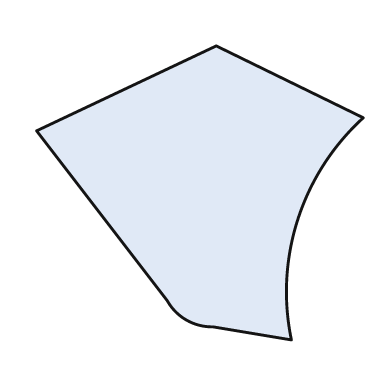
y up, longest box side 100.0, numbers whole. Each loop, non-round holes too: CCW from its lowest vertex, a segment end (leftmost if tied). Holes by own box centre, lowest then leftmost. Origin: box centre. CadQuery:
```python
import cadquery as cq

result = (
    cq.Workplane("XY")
    .moveTo(28.0, -45.0)
    .threePointArc((30.0, -8.0), (50.0, 23.0))
    .lineTo(5.0, 45.0)
    .lineTo(-50.0, 19.0)
    .lineTo(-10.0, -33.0)
    .threePointArc((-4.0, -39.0), (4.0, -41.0))
    .close()
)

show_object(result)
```